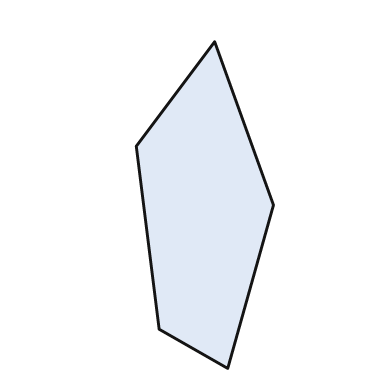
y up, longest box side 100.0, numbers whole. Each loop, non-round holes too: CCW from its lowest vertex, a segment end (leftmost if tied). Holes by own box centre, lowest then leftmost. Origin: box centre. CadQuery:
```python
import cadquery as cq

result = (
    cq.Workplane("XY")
    .moveTo(7.0, -50.0)
    .lineTo(21.0, 0.0)
    .lineTo(3.0, 50.0)
    .lineTo(-21.0, 18.0)
    .lineTo(-14.0, -38.0)
    .close()
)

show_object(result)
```